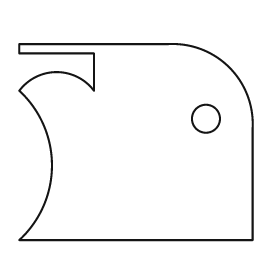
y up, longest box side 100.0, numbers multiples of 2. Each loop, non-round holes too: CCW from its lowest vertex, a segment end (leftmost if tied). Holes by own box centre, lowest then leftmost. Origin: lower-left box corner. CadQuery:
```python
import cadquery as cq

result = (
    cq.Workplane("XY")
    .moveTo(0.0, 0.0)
    .lineTo(100.0, 0.0)
    .lineTo(100.0, 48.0)
    .threePointArc((90.0, 74.0), (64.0, 84.0))
    .lineTo(0.0, 84.0)
    .lineTo(0.0, 80.0)
    .lineTo(32.0, 80.0)
    .lineTo(32.0, 64.0)
    .threePointArc((16.0, 72.0), (0.0, 64.0))
    .threePointArc((14.0, 32.0), (0.0, 0.0))
    .close()
    .moveTo(80.0, 52.0)
    .circle(6.0)
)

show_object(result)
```